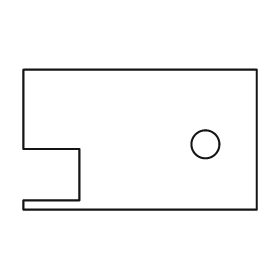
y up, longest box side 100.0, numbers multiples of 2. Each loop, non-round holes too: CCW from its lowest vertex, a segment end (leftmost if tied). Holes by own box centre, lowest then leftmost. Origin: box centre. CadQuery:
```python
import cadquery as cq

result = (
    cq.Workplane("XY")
    .moveTo(-50.0, -30.0)
    .lineTo(50.0, -30.0)
    .lineTo(50.0, 30.0)
    .lineTo(-50.0, 30.0)
    .lineTo(-50.0, -4.0)
    .lineTo(-26.0, -4.0)
    .lineTo(-26.0, -26.0)
    .lineTo(-50.0, -26.0)
    .close()
    .moveTo(28.0, -2.0)
    .circle(6.0)
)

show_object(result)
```